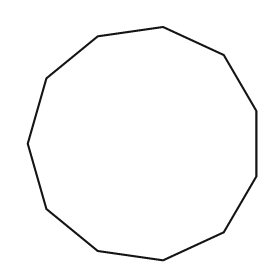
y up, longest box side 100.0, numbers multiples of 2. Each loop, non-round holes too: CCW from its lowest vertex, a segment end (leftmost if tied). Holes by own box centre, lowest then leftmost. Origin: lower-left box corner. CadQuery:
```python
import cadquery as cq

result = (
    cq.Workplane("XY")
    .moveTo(58.0, 0.0)
    .lineTo(84.0, 12.0)
    .lineTo(98.0, 36.0)
    .lineTo(98.0, 64.0)
    .lineTo(84.0, 88.0)
    .lineTo(58.0, 100.0)
    .lineTo(30.0, 96.0)
    .lineTo(8.0, 78.0)
    .lineTo(0.0, 50.0)
    .lineTo(8.0, 22.0)
    .lineTo(30.0, 4.0)
    .close()
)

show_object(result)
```